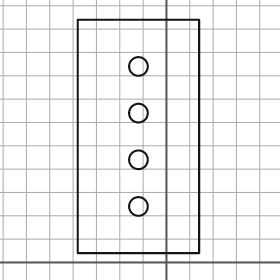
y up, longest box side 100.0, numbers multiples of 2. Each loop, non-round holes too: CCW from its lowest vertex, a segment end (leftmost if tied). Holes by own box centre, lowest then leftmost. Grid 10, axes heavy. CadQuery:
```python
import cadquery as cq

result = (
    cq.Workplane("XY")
    .moveTo(-38.0, 4.0)
    .lineTo(14.0, 4.0)
    .lineTo(14.0, 104.0)
    .lineTo(-38.0, 104.0)
    .close()
    .moveTo(-12.0, 24.0)
    .circle(4.0)
    .moveTo(-12.0, 44.0)
    .circle(4.0)
    .moveTo(-12.0, 64.0)
    .circle(4.0)
    .moveTo(-12.0, 84.0)
    .circle(4.0)
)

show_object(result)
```